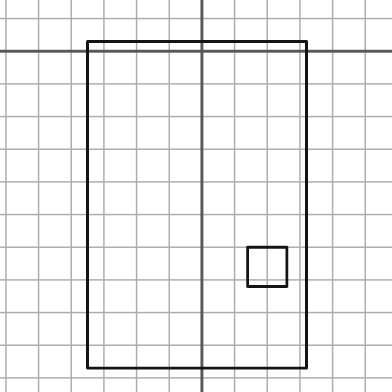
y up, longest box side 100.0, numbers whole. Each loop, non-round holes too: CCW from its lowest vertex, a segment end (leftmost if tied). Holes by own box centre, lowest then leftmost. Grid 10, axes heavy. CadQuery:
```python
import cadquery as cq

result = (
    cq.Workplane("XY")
    .moveTo(-35.0, -97.0)
    .lineTo(32.0, -97.0)
    .lineTo(32.0, 3.0)
    .lineTo(-35.0, 3.0)
    .close()
    .moveTo(14.0, -72.0)
    .lineTo(26.0, -72.0)
    .lineTo(26.0, -60.0)
    .lineTo(14.0, -60.0)
    .close()
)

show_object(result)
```